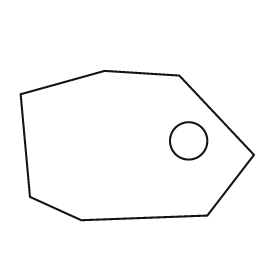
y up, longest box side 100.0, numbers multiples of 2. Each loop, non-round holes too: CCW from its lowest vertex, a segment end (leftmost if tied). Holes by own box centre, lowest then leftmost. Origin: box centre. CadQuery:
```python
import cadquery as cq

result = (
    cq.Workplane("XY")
    .moveTo(-24.0, -32.0)
    .lineTo(30.0, -30.0)
    .lineTo(50.0, -4.0)
    .lineTo(18.0, 30.0)
    .lineTo(-14.0, 32.0)
    .lineTo(-50.0, 22.0)
    .lineTo(-46.0, -22.0)
    .close()
    .moveTo(22.0, 2.0)
    .circle(8.0)
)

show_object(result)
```